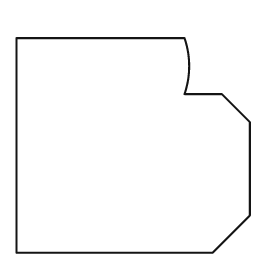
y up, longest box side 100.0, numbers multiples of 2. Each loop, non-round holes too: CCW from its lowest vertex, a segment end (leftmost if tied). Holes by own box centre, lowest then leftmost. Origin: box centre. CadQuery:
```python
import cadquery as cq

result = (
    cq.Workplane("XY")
    .moveTo(-50.0, -46.0)
    .lineTo(34.0, -46.0)
    .lineTo(50.0, -30.0)
    .lineTo(50.0, 10.0)
    .lineTo(38.0, 22.0)
    .lineTo(22.0, 22.0)
    .threePointArc((24.0, 34.0), (22.0, 46.0))
    .lineTo(-50.0, 46.0)
    .close()
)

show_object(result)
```